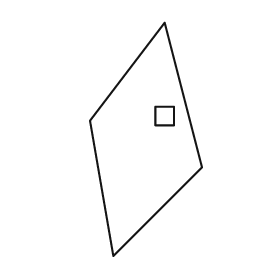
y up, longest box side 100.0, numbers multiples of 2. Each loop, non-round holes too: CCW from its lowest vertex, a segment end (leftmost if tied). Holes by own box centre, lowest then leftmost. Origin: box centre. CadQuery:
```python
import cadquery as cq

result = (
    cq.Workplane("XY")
    .moveTo(-14.0, -50.0)
    .lineTo(24.0, -12.0)
    .lineTo(8.0, 50.0)
    .lineTo(-24.0, 8.0)
    .close()
    .moveTo(4.0, 6.0)
    .lineTo(12.0, 6.0)
    .lineTo(12.0, 14.0)
    .lineTo(4.0, 14.0)
    .close()
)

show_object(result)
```